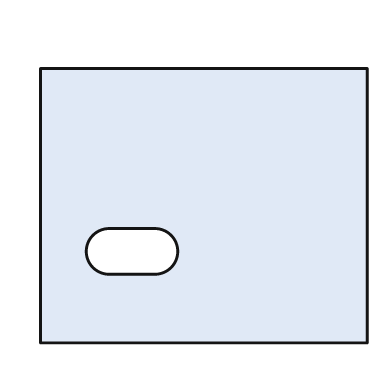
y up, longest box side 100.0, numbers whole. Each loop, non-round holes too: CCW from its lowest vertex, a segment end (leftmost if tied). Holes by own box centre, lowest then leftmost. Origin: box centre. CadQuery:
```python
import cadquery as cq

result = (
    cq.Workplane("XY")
    .moveTo(-50.0, -42.0)
    .lineTo(50.0, -42.0)
    .lineTo(50.0, 42.0)
    .lineTo(-50.0, 42.0)
    .close()
    .moveTo(-29.0, -21.0)
    .lineTo(-15.0, -21.0)
    .threePointArc((-8.0, -14.0), (-15.0, -7.0))
    .lineTo(-29.0, -7.0)
    .threePointArc((-36.0, -14.0), (-29.0, -21.0))
    .close()
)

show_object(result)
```